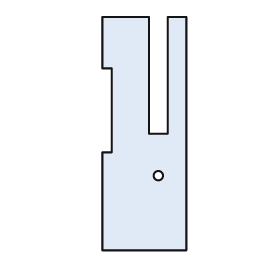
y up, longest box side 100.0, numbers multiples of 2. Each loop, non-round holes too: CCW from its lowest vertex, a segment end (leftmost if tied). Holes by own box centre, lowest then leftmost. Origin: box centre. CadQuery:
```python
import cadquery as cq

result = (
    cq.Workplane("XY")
    .moveTo(-18.0, -50.0)
    .lineTo(18.0, -50.0)
    .lineTo(18.0, 50.0)
    .lineTo(10.0, 50.0)
    .lineTo(10.0, 0.0)
    .lineTo(2.0, 0.0)
    .lineTo(2.0, 50.0)
    .lineTo(-18.0, 50.0)
    .lineTo(-18.0, 28.0)
    .lineTo(-14.0, 28.0)
    .lineTo(-14.0, -8.0)
    .lineTo(-18.0, -8.0)
    .close()
    .moveTo(6.0, -18.0)
    .circle(2.0)
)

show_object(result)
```